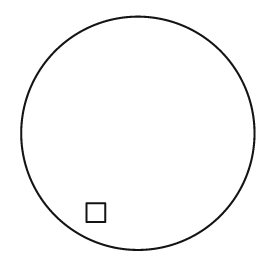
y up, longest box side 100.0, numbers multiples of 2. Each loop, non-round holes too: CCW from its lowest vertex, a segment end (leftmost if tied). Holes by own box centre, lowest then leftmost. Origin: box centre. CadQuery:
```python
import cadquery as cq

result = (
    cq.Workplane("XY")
    .moveTo(0.0, 0.0)
    .circle(50.0)
    .moveTo(-22.0, -38.0)
    .lineTo(-14.0, -38.0)
    .lineTo(-14.0, -30.0)
    .lineTo(-22.0, -30.0)
    .close()
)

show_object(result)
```